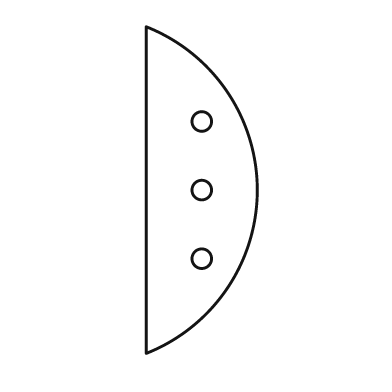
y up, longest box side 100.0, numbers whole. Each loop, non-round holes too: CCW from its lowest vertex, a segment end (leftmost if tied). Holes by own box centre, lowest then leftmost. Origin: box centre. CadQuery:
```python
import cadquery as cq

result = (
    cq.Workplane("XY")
    .moveTo(-17.0, -50.0)
    .threePointArc((17.0, 0.0), (-17.0, 50.0))
    .close()
    .moveTo(0.0, -21.0)
    .circle(3.0)
    .moveTo(0.0, 0.0)
    .circle(3.0)
    .moveTo(0.0, 21.0)
    .circle(3.0)
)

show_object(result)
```